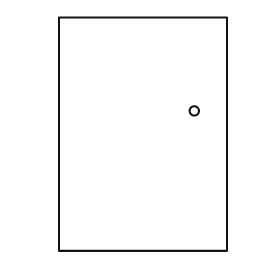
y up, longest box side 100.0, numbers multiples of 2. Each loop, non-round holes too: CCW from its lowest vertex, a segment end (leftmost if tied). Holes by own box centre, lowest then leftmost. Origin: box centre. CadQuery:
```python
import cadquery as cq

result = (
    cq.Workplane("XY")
    .moveTo(-36.0, -50.0)
    .lineTo(36.0, -50.0)
    .lineTo(36.0, 50.0)
    .lineTo(-36.0, 50.0)
    .close()
    .moveTo(22.0, 10.0)
    .circle(2.0)
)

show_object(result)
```